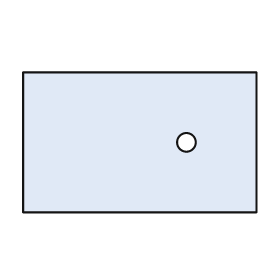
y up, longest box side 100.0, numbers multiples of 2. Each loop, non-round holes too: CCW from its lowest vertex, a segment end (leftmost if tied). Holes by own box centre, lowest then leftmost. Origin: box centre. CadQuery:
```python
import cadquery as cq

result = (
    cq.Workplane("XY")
    .moveTo(-50.0, -30.0)
    .lineTo(50.0, -30.0)
    .lineTo(50.0, 30.0)
    .lineTo(-50.0, 30.0)
    .close()
    .moveTo(20.0, 0.0)
    .circle(4.0)
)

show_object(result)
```